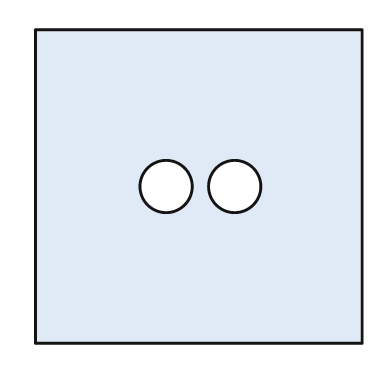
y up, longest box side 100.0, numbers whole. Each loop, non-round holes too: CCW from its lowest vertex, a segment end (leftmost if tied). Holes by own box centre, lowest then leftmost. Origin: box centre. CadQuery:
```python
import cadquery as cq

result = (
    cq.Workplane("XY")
    .moveTo(-50.0, -48.0)
    .lineTo(50.0, -48.0)
    .lineTo(50.0, 48.0)
    .lineTo(-50.0, 48.0)
    .close()
    .moveTo(-10.0, 0.0)
    .circle(8.0)
    .moveTo(11.0, 0.0)
    .circle(8.0)
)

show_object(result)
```